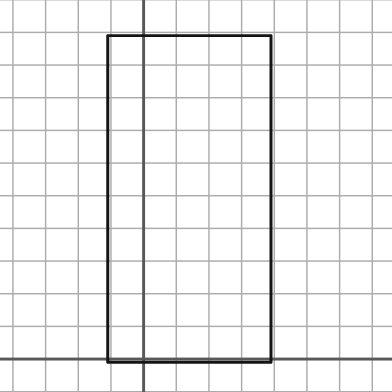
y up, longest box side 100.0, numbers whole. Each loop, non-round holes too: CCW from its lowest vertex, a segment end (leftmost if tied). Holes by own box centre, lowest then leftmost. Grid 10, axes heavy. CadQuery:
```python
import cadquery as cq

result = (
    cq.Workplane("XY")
    .moveTo(-11.0, -1.0)
    .lineTo(39.0, -1.0)
    .lineTo(39.0, 99.0)
    .lineTo(-11.0, 99.0)
    .close()
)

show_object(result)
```